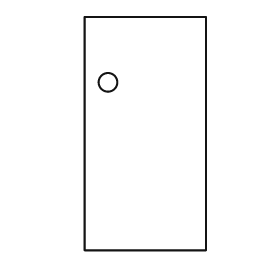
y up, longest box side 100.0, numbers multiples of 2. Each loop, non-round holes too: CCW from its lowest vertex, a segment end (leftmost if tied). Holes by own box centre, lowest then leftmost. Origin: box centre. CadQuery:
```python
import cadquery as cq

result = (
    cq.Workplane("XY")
    .moveTo(-26.0, -50.0)
    .lineTo(26.0, -50.0)
    .lineTo(26.0, 50.0)
    .lineTo(-26.0, 50.0)
    .close()
    .moveTo(-16.0, 22.0)
    .circle(4.0)
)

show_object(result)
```